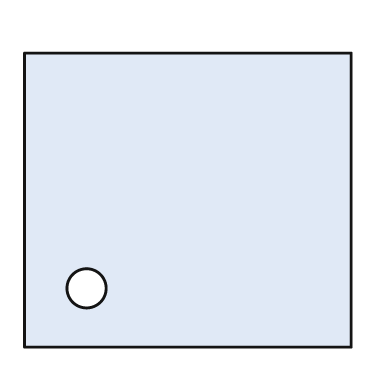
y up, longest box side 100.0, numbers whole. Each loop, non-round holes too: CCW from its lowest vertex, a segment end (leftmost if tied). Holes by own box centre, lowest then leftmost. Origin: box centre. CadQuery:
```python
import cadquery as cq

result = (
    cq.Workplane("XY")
    .moveTo(-50.0, -45.0)
    .lineTo(50.0, -45.0)
    .lineTo(50.0, 45.0)
    .lineTo(-50.0, 45.0)
    .close()
    .moveTo(-31.0, -27.0)
    .circle(6.0)
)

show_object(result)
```